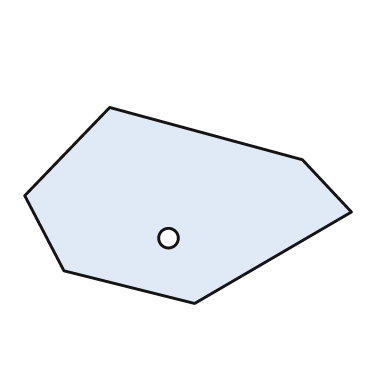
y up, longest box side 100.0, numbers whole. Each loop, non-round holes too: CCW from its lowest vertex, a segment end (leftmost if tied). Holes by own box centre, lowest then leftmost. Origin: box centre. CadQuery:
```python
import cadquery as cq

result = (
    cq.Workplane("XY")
    .moveTo(2.0, -30.0)
    .lineTo(50.0, -2.0)
    .lineTo(35.0, 14.0)
    .lineTo(-24.0, 30.0)
    .lineTo(-50.0, 3.0)
    .lineTo(-38.0, -20.0)
    .close()
    .moveTo(-6.0, -10.0)
    .circle(3.0)
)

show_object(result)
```